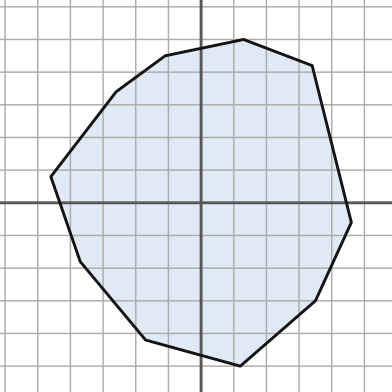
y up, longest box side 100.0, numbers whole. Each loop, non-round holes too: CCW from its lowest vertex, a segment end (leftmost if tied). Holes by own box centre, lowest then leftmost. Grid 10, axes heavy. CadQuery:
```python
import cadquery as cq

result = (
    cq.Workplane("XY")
    .moveTo(12.0, -50.0)
    .lineTo(35.0, -30.0)
    .lineTo(46.0, -6.0)
    .lineTo(34.0, 42.0)
    .lineTo(13.0, 50.0)
    .lineTo(-11.0, 45.0)
    .lineTo(-26.0, 34.0)
    .lineTo(-46.0, 8.0)
    .lineTo(-37.0, -18.0)
    .lineTo(-17.0, -42.0)
    .close()
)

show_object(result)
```